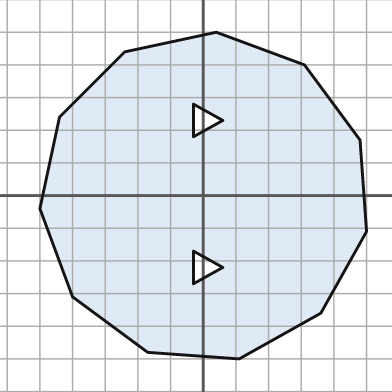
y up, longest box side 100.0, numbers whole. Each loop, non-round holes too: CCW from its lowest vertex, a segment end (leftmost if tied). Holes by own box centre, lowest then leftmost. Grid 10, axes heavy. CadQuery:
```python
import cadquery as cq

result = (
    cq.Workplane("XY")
    .moveTo(11.0, -50.0)
    .lineTo(36.0, -36.0)
    .lineTo(50.0, -11.0)
    .lineTo(48.0, 17.0)
    .lineTo(31.0, 40.0)
    .lineTo(4.0, 50.0)
    .lineTo(-24.0, 44.0)
    .lineTo(-44.0, 24.0)
    .lineTo(-50.0, -4.0)
    .lineTo(-40.0, -31.0)
    .lineTo(-17.0, -48.0)
    .close()
    .moveTo(-3.0, -27.0)
    .lineTo(6.0, -22.0)
    .lineTo(-3.0, -17.0)
    .close()
    .moveTo(-3.0, 18.0)
    .lineTo(6.0, 23.0)
    .lineTo(-3.0, 28.0)
    .close()
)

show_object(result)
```